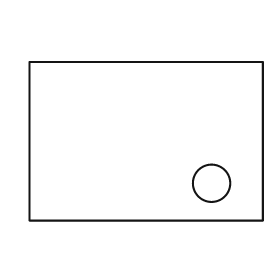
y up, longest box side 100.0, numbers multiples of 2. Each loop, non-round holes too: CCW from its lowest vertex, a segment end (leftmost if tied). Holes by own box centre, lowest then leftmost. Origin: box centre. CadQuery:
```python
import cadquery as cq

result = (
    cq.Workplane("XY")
    .moveTo(-50.0, -34.0)
    .lineTo(50.0, -34.0)
    .lineTo(50.0, 34.0)
    .lineTo(-50.0, 34.0)
    .close()
    .moveTo(28.0, -18.0)
    .circle(8.0)
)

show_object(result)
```